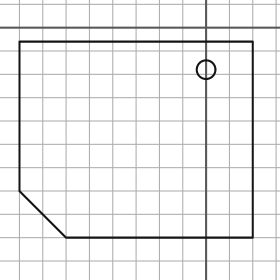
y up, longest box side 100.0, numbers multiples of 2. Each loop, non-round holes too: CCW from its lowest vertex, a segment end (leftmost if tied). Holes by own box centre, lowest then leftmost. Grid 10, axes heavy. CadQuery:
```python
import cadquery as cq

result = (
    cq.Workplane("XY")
    .moveTo(-60.0, -90.0)
    .lineTo(20.0, -90.0)
    .lineTo(20.0, -6.0)
    .lineTo(-80.0, -6.0)
    .lineTo(-80.0, -70.0)
    .close()
    .moveTo(0.0, -18.0)
    .circle(4.0)
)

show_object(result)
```